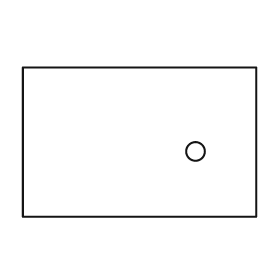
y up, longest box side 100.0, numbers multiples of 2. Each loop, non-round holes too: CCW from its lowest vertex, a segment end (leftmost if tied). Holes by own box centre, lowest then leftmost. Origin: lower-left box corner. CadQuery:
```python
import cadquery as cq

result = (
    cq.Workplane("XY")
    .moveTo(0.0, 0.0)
    .lineTo(100.0, 0.0)
    .lineTo(100.0, 64.0)
    .lineTo(0.0, 64.0)
    .close()
    .moveTo(74.0, 28.0)
    .circle(4.0)
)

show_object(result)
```